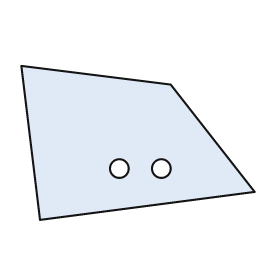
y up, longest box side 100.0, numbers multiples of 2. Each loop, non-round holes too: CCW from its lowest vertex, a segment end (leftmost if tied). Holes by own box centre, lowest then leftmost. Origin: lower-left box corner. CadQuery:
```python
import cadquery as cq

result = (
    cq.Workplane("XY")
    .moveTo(8.0, 0.0)
    .lineTo(100.0, 12.0)
    .lineTo(64.0, 58.0)
    .lineTo(0.0, 66.0)
    .close()
    .moveTo(42.0, 22.0)
    .circle(4.0)
    .moveTo(60.0, 22.0)
    .circle(4.0)
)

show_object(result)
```